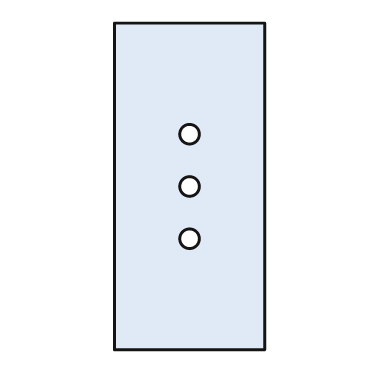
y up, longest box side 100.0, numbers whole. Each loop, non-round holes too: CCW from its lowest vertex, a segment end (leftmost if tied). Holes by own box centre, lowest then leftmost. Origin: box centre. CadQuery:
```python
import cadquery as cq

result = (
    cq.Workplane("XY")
    .moveTo(-23.0, -50.0)
    .lineTo(23.0, -50.0)
    .lineTo(23.0, 50.0)
    .lineTo(-23.0, 50.0)
    .close()
    .moveTo(0.0, -16.0)
    .circle(3.0)
    .moveTo(0.0, 0.0)
    .circle(3.0)
    .moveTo(0.0, 16.0)
    .circle(3.0)
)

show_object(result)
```